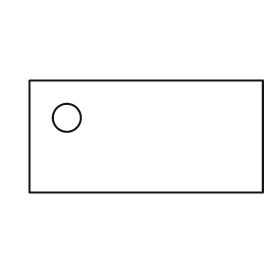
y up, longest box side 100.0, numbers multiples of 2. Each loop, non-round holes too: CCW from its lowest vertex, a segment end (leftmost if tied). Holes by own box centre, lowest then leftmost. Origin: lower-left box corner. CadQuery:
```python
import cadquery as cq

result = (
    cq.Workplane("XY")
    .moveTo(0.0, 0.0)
    .lineTo(100.0, 0.0)
    .lineTo(100.0, 48.0)
    .lineTo(0.0, 48.0)
    .close()
    .moveTo(16.0, 32.0)
    .circle(6.0)
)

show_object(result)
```